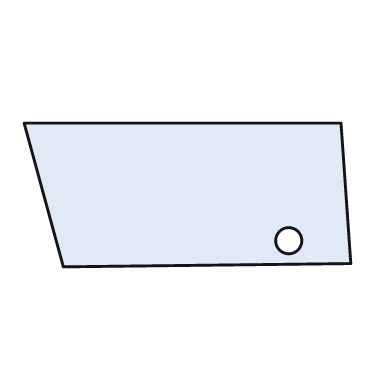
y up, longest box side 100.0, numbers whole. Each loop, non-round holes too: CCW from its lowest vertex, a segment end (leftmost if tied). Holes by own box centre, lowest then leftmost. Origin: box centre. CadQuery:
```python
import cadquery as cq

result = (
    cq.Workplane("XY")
    .moveTo(-38.0, -22.0)
    .lineTo(50.0, -21.0)
    .lineTo(47.0, 22.0)
    .lineTo(-50.0, 22.0)
    .close()
    .moveTo(31.0, -14.0)
    .circle(4.0)
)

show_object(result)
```